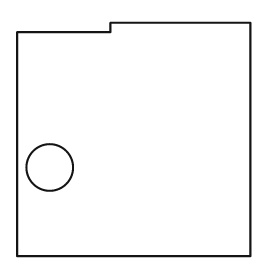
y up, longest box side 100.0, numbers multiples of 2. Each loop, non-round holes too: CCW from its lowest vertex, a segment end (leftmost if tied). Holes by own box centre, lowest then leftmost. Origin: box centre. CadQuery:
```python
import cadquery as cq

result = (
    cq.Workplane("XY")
    .moveTo(-50.0, -50.0)
    .lineTo(50.0, -50.0)
    .lineTo(50.0, 50.0)
    .lineTo(-10.0, 50.0)
    .lineTo(-10.0, 46.0)
    .lineTo(-50.0, 46.0)
    .close()
    .moveTo(-36.0, -12.0)
    .circle(10.0)
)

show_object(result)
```